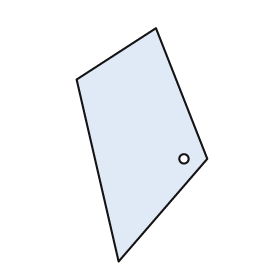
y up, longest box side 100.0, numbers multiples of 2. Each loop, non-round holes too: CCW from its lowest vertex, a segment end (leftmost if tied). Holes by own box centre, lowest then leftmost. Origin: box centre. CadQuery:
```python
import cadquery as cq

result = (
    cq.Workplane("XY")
    .moveTo(-10.0, -50.0)
    .lineTo(28.0, -6.0)
    .lineTo(6.0, 50.0)
    .lineTo(-28.0, 28.0)
    .close()
    .moveTo(18.0, -6.0)
    .circle(2.0)
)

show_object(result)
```